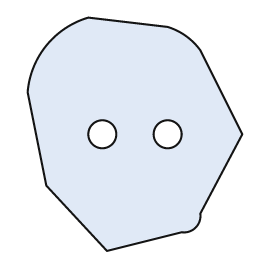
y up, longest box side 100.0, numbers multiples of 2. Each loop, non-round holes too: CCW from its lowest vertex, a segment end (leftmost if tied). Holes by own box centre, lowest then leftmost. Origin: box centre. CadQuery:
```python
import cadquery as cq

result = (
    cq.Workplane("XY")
    .moveTo(-12.0, -50.0)
    .lineTo(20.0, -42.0)
    .threePointArc((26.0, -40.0), (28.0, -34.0))
    .lineTo(46.0, 0.0)
    .lineTo(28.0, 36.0)
    .threePointArc((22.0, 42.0), (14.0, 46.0))
    .lineTo(-20.0, 50.0)
    .threePointArc((-38.0, 38.0), (-46.0, 18.0))
    .lineTo(-38.0, -22.0)
    .close()
    .moveTo(-14.0, 0.0)
    .circle(6.0)
    .moveTo(14.0, 0.0)
    .circle(6.0)
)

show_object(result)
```